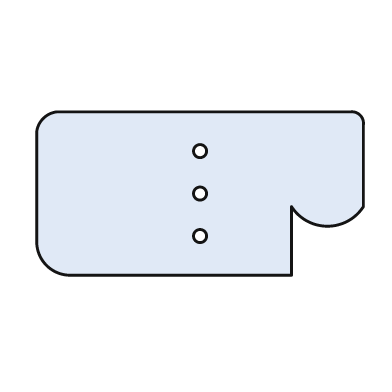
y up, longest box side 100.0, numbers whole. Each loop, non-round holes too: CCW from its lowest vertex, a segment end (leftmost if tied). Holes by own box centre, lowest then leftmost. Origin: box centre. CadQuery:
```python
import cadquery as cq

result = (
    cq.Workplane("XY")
    .moveTo(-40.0, -25.0)
    .lineTo(28.0, -25.0)
    .lineTo(28.0, -4.0)
    .threePointArc((39.0, -10.0), (50.0, -4.0))
    .lineTo(50.0, 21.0)
    .threePointArc((49.0, 24.0), (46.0, 25.0))
    .lineTo(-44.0, 25.0)
    .threePointArc((-48.0, 23.0), (-50.0, 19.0))
    .lineTo(-50.0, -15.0)
    .threePointArc((-47.0, -22.0), (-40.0, -25.0))
    .close()
    .moveTo(0.0, -13.0)
    .circle(2.0)
    .moveTo(0.0, 0.0)
    .circle(2.0)
    .moveTo(0.0, 13.0)
    .circle(2.0)
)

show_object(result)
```